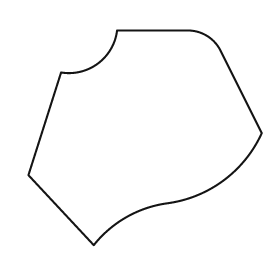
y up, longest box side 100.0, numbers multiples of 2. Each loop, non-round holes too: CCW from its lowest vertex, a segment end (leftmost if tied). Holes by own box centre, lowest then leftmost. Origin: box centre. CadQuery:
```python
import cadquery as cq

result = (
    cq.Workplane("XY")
    .moveTo(-22.0, -46.0)
    .threePointArc((-8.0, -34.0), (10.0, -28.0))
    .threePointArc((34.0, -18.0), (50.0, 2.0))
    .lineTo(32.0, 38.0)
    .threePointArc((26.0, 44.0), (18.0, 46.0))
    .lineTo(-12.0, 46.0)
    .threePointArc((-20.0, 32.0), (-36.0, 28.0))
    .lineTo(-50.0, -16.0)
    .close()
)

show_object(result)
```